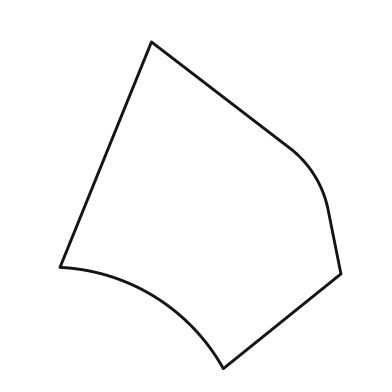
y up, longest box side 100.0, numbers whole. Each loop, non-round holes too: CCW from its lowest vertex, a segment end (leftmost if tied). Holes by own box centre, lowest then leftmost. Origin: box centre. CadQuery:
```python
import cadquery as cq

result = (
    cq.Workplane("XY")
    .moveTo(7.0, -50.0)
    .lineTo(43.0, -21.0)
    .lineTo(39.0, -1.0)
    .threePointArc((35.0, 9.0), (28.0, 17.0))
    .lineTo(-15.0, 50.0)
    .lineTo(-43.0, -19.0)
    .threePointArc((-14.0, -28.0), (7.0, -50.0))
    .close()
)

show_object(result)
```